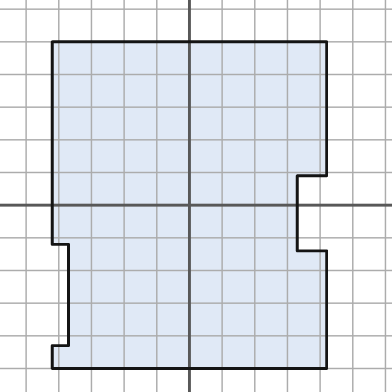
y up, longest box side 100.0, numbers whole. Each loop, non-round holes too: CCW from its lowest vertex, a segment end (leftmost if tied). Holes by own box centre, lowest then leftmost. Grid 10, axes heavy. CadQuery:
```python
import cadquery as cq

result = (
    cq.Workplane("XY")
    .moveTo(-42.0, -50.0)
    .lineTo(42.0, -50.0)
    .lineTo(42.0, -14.0)
    .lineTo(33.0, -14.0)
    .lineTo(33.0, 9.0)
    .lineTo(42.0, 9.0)
    .lineTo(42.0, 50.0)
    .lineTo(-42.0, 50.0)
    .lineTo(-42.0, -12.0)
    .lineTo(-37.0, -12.0)
    .lineTo(-37.0, -43.0)
    .lineTo(-42.0, -43.0)
    .close()
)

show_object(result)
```